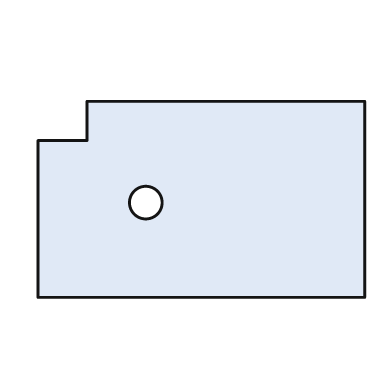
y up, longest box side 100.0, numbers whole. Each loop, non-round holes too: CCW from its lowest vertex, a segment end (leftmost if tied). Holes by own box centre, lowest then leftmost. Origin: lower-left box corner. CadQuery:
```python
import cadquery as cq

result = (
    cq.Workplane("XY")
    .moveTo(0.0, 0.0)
    .lineTo(100.0, 0.0)
    .lineTo(100.0, 60.0)
    .lineTo(15.0, 60.0)
    .lineTo(15.0, 48.0)
    .lineTo(0.0, 48.0)
    .close()
    .moveTo(33.0, 29.0)
    .circle(5.0)
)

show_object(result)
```